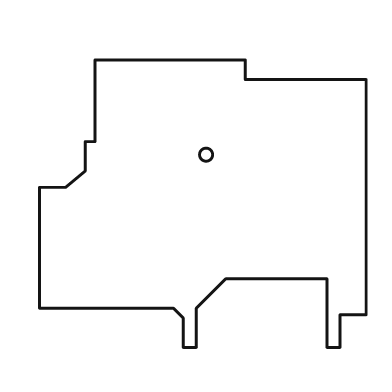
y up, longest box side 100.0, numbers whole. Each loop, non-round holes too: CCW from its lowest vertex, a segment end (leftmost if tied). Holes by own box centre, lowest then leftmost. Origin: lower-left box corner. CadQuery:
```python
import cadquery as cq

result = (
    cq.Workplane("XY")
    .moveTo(44.0, 0.0)
    .lineTo(48.0, 0.0)
    .lineTo(48.0, 12.0)
    .lineTo(57.0, 21.0)
    .lineTo(88.0, 21.0)
    .lineTo(88.0, 0.0)
    .lineTo(92.0, 0.0)
    .lineTo(92.0, 10.0)
    .lineTo(100.0, 10.0)
    .lineTo(100.0, 82.0)
    .lineTo(63.0, 82.0)
    .lineTo(63.0, 88.0)
    .lineTo(17.0, 88.0)
    .lineTo(17.0, 63.0)
    .lineTo(14.0, 63.0)
    .lineTo(14.0, 54.0)
    .lineTo(8.0, 49.0)
    .lineTo(0.0, 49.0)
    .lineTo(0.0, 12.0)
    .lineTo(41.0, 12.0)
    .lineTo(44.0, 9.0)
    .close()
    .moveTo(51.0, 59.0)
    .circle(2.0)
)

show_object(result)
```